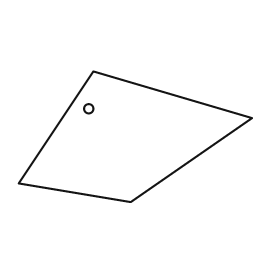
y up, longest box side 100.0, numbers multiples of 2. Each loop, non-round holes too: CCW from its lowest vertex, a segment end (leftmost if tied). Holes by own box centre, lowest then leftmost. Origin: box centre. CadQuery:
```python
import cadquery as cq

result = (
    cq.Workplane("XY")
    .moveTo(-2.0, -28.0)
    .lineTo(50.0, 8.0)
    .lineTo(-18.0, 28.0)
    .lineTo(-50.0, -20.0)
    .close()
    .moveTo(-20.0, 12.0)
    .circle(2.0)
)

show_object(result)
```